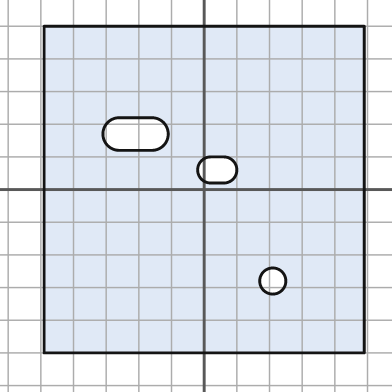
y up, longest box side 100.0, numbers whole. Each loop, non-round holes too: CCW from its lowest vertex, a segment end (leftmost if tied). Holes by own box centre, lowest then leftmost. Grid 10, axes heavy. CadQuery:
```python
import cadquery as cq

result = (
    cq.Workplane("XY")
    .moveTo(-49.0, -50.0)
    .lineTo(49.0, -50.0)
    .lineTo(49.0, 50.0)
    .lineTo(-49.0, 50.0)
    .close()
    .moveTo(21.0, -28.0)
    .circle(4.0)
    .moveTo(2.0, 2.0)
    .lineTo(6.0, 2.0)
    .threePointArc((10.0, 6.0), (6.0, 10.0))
    .lineTo(2.0, 10.0)
    .threePointArc((-2.0, 6.0), (2.0, 2.0))
    .close()
    .moveTo(-26.0, 12.0)
    .lineTo(-16.0, 12.0)
    .threePointArc((-11.0, 17.0), (-16.0, 22.0))
    .lineTo(-26.0, 22.0)
    .threePointArc((-31.0, 17.0), (-26.0, 12.0))
    .close()
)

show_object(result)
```